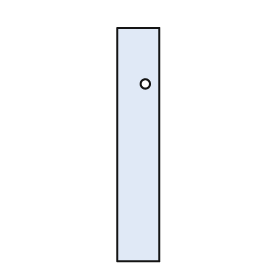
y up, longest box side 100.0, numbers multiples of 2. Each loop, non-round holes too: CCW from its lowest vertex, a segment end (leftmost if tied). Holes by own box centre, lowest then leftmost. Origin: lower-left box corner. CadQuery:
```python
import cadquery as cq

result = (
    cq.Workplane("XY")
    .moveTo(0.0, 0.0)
    .lineTo(18.0, 0.0)
    .lineTo(18.0, 100.0)
    .lineTo(0.0, 100.0)
    .close()
    .moveTo(12.0, 76.0)
    .circle(2.0)
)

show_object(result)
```